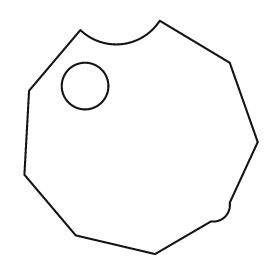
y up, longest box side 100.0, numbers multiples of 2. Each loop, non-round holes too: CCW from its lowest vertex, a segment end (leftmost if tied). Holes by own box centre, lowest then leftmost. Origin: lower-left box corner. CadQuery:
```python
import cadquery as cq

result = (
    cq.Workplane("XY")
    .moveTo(56.0, 0.0)
    .lineTo(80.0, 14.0)
    .threePointArc((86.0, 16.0), (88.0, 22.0))
    .lineTo(100.0, 48.0)
    .lineTo(88.0, 82.0)
    .lineTo(58.0, 100.0)
    .threePointArc((42.0, 90.0), (24.0, 96.0))
    .lineTo(2.0, 70.0)
    .lineTo(0.0, 34.0)
    .lineTo(22.0, 8.0)
    .close()
    .moveTo(26.0, 72.0)
    .circle(10.0)
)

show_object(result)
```